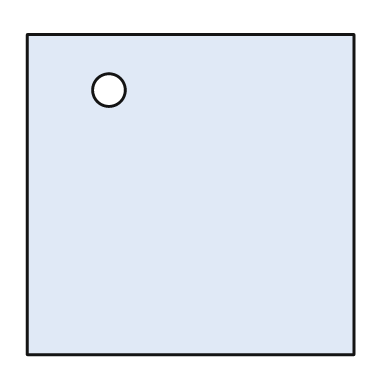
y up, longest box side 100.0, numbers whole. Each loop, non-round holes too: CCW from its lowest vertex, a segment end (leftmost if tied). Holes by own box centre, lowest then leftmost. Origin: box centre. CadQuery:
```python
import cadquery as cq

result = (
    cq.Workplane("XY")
    .moveTo(-50.0, -49.0)
    .lineTo(50.0, -49.0)
    .lineTo(50.0, 49.0)
    .lineTo(-50.0, 49.0)
    .close()
    .moveTo(-25.0, 32.0)
    .circle(5.0)
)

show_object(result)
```